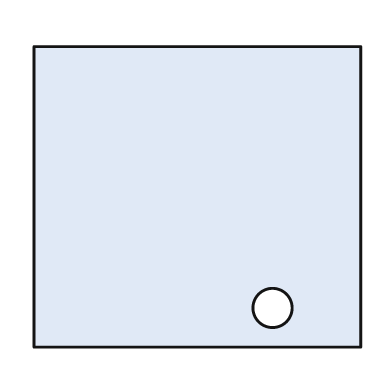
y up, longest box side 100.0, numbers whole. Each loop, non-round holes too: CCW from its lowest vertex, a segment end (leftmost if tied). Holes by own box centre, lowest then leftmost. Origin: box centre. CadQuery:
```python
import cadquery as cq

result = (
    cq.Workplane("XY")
    .moveTo(-50.0, -46.0)
    .lineTo(50.0, -46.0)
    .lineTo(50.0, 46.0)
    .lineTo(-50.0, 46.0)
    .close()
    .moveTo(23.0, -34.0)
    .circle(6.0)
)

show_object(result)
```